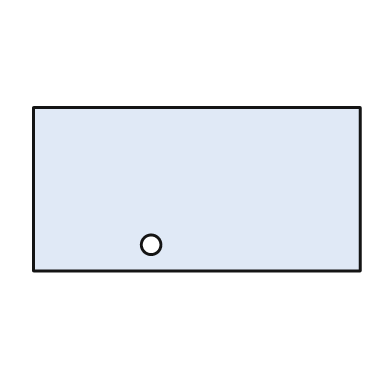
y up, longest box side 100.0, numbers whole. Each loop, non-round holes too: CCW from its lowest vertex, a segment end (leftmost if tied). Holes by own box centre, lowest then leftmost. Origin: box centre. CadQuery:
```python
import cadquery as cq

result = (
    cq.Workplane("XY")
    .moveTo(-50.0, -25.0)
    .lineTo(50.0, -25.0)
    .lineTo(50.0, 25.0)
    .lineTo(-50.0, 25.0)
    .close()
    .moveTo(-14.0, -17.0)
    .circle(3.0)
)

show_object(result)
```